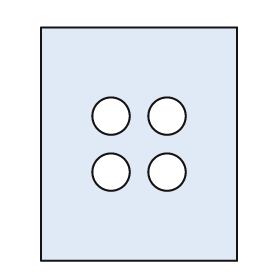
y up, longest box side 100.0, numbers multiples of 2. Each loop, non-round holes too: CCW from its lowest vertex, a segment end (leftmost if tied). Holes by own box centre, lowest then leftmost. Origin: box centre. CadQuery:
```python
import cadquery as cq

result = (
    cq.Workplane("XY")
    .moveTo(-42.0, -50.0)
    .lineTo(42.0, -50.0)
    .lineTo(42.0, 50.0)
    .lineTo(-42.0, 50.0)
    .close()
    .moveTo(-12.0, -12.0)
    .circle(8.0)
    .moveTo(12.0, -12.0)
    .circle(8.0)
    .moveTo(-12.0, 12.0)
    .circle(8.0)
    .moveTo(12.0, 12.0)
    .circle(8.0)
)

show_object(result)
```